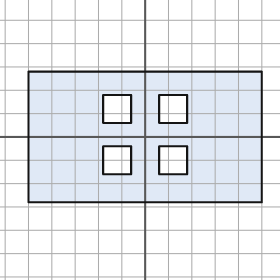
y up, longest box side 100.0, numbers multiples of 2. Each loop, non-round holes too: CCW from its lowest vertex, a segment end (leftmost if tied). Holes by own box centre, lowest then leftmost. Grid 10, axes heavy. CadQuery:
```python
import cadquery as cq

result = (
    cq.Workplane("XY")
    .moveTo(-50.0, -28.0)
    .lineTo(50.0, -28.0)
    .lineTo(50.0, 28.0)
    .lineTo(-50.0, 28.0)
    .close()
    .moveTo(-18.0, -16.0)
    .lineTo(-6.0, -16.0)
    .lineTo(-6.0, -4.0)
    .lineTo(-18.0, -4.0)
    .close()
    .moveTo(6.0, -16.0)
    .lineTo(18.0, -16.0)
    .lineTo(18.0, -4.0)
    .lineTo(6.0, -4.0)
    .close()
    .moveTo(-18.0, 6.0)
    .lineTo(-6.0, 6.0)
    .lineTo(-6.0, 18.0)
    .lineTo(-18.0, 18.0)
    .close()
    .moveTo(6.0, 6.0)
    .lineTo(18.0, 6.0)
    .lineTo(18.0, 18.0)
    .lineTo(6.0, 18.0)
    .close()
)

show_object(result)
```